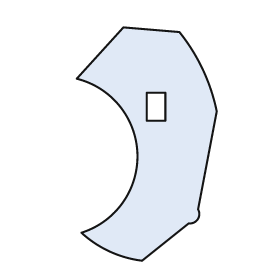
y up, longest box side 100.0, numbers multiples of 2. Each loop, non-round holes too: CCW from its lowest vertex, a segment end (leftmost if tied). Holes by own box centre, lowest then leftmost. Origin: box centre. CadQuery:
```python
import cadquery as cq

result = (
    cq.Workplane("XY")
    .moveTo(-2.0, -50.0)
    .lineTo(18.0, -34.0)
    .threePointArc((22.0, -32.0), (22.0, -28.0))
    .lineTo(30.0, 14.0)
    .threePointArc((24.0, 32.0), (14.0, 48.0))
    .lineTo(-10.0, 50.0)
    .lineTo(-30.0, 28.0)
    .threePointArc((-4.0, -4.0), (-28.0, -38.0))
    .threePointArc((-16.0, -46.0), (-2.0, -50.0))
    .close()
    .moveTo(0.0, 10.0)
    .lineTo(8.0, 10.0)
    .lineTo(8.0, 22.0)
    .lineTo(0.0, 22.0)
    .close()
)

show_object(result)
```